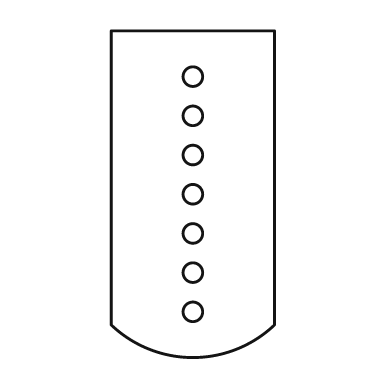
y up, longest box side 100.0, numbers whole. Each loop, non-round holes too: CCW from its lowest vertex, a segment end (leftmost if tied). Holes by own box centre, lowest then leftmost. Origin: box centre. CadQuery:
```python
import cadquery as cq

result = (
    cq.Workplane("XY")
    .moveTo(-25.0, -40.0)
    .threePointArc((0.0, -50.0), (25.0, -40.0))
    .lineTo(25.0, 50.0)
    .lineTo(-25.0, 50.0)
    .close()
    .moveTo(0.0, -36.0)
    .circle(3.0)
    .moveTo(0.0, -24.0)
    .circle(3.0)
    .moveTo(0.0, -12.0)
    .circle(3.0)
    .moveTo(0.0, 0.0)
    .circle(3.0)
    .moveTo(0.0, 12.0)
    .circle(3.0)
    .moveTo(0.0, 24.0)
    .circle(3.0)
    .moveTo(0.0, 36.0)
    .circle(3.0)
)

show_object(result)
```